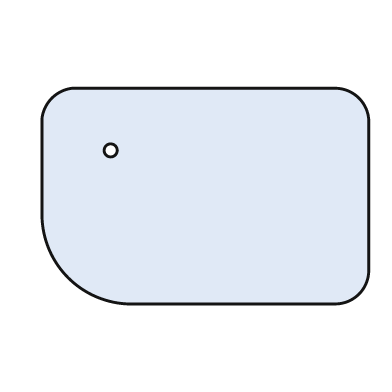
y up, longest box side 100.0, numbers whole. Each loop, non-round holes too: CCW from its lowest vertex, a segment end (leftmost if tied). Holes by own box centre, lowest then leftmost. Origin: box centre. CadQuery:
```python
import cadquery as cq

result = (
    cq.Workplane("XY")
    .moveTo(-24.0, -33.0)
    .lineTo(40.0, -33.0)
    .threePointArc((47.0, -30.0), (50.0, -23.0))
    .lineTo(50.0, 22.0)
    .threePointArc((47.0, 30.0), (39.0, 33.0))
    .lineTo(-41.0, 33.0)
    .threePointArc((-47.0, 30.0), (-50.0, 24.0))
    .lineTo(-50.0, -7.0)
    .threePointArc((-42.0, -25.0), (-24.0, -33.0))
    .close()
    .moveTo(-29.0, 14.0)
    .circle(2.0)
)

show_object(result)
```